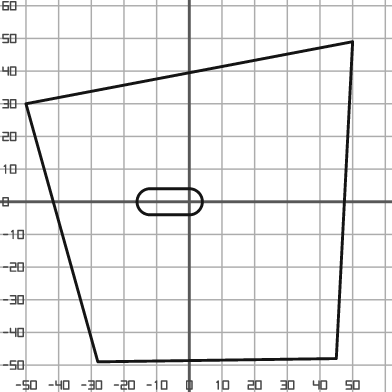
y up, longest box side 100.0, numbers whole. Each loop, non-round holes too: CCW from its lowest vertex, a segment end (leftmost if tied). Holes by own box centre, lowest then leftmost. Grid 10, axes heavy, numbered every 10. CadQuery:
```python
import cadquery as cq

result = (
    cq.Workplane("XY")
    .moveTo(-28.0, -49.0)
    .lineTo(45.0, -48.0)
    .lineTo(50.0, 49.0)
    .lineTo(-50.0, 30.0)
    .close()
    .moveTo(-12.0, -4.0)
    .lineTo(0.0, -4.0)
    .threePointArc((4.0, 0.0), (0.0, 4.0))
    .lineTo(-12.0, 4.0)
    .threePointArc((-16.0, 0.0), (-12.0, -4.0))
    .close()
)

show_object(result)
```